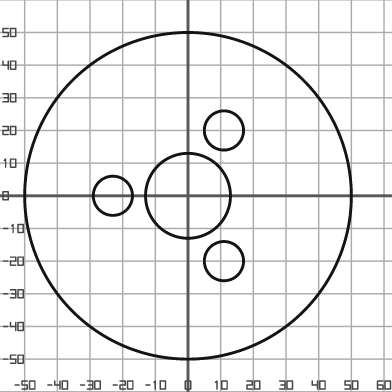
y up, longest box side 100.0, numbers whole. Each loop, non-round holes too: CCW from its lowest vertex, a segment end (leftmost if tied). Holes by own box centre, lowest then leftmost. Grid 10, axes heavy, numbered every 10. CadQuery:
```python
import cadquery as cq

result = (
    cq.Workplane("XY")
    .moveTo(0.0, 0.0)
    .circle(50.0)
    .moveTo(11.0, -20.0)
    .circle(6.0)
    .moveTo(-23.0, 0.0)
    .circle(6.0)
    .moveTo(0.0, 0.0)
    .circle(13.0)
    .moveTo(11.0, 20.0)
    .circle(6.0)
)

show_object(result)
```